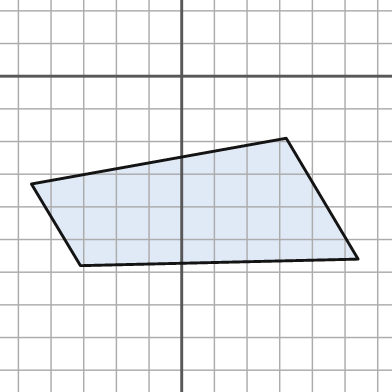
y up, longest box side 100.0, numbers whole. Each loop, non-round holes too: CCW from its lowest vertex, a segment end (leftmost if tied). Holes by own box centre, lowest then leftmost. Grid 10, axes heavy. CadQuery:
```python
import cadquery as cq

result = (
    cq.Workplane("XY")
    .moveTo(-31.0, -58.0)
    .lineTo(54.0, -56.0)
    .lineTo(32.0, -19.0)
    .lineTo(-46.0, -33.0)
    .close()
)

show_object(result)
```